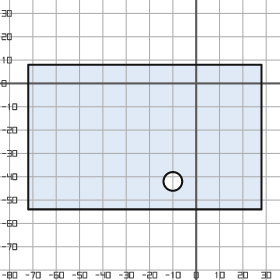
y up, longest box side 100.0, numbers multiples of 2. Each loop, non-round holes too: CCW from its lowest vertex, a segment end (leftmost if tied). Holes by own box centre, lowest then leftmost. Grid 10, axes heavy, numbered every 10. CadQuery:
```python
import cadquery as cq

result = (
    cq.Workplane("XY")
    .moveTo(-72.0, -54.0)
    .lineTo(28.0, -54.0)
    .lineTo(28.0, 8.0)
    .lineTo(-72.0, 8.0)
    .close()
    .moveTo(-10.0, -42.0)
    .circle(4.0)
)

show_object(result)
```